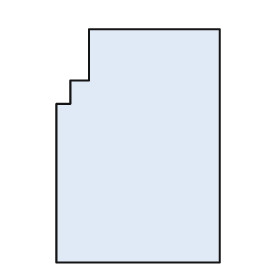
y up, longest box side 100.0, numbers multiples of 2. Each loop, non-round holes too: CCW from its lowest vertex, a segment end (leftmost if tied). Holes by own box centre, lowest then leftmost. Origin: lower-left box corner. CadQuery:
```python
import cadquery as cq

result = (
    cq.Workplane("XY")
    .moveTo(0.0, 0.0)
    .lineTo(70.0, 0.0)
    .lineTo(70.0, 100.0)
    .lineTo(14.0, 100.0)
    .lineTo(14.0, 78.0)
    .lineTo(6.0, 78.0)
    .lineTo(6.0, 68.0)
    .lineTo(0.0, 68.0)
    .close()
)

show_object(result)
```